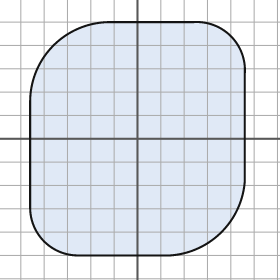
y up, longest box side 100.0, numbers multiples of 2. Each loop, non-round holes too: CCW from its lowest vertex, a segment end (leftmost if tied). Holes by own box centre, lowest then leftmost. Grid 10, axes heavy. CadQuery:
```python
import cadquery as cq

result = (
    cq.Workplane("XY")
    .moveTo(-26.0, -50.0)
    .lineTo(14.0, -50.0)
    .threePointArc((36.0, -40.0), (46.0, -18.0))
    .lineTo(46.0, 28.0)
    .threePointArc((40.0, 44.0), (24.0, 50.0))
    .lineTo(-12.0, 50.0)
    .threePointArc((-36.0, 40.0), (-46.0, 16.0))
    .lineTo(-46.0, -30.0)
    .threePointArc((-40.0, -44.0), (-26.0, -50.0))
    .close()
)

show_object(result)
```